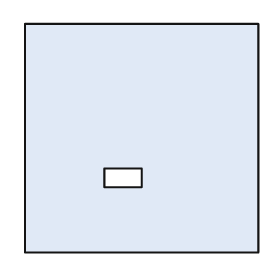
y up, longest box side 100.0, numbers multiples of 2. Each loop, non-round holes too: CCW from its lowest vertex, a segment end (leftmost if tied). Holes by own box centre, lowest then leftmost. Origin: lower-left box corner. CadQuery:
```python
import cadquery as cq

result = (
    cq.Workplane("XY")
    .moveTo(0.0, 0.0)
    .lineTo(100.0, 0.0)
    .lineTo(100.0, 98.0)
    .lineTo(0.0, 98.0)
    .close()
    .moveTo(34.0, 28.0)
    .lineTo(50.0, 28.0)
    .lineTo(50.0, 36.0)
    .lineTo(34.0, 36.0)
    .close()
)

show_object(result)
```